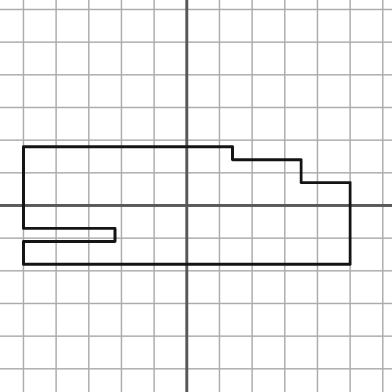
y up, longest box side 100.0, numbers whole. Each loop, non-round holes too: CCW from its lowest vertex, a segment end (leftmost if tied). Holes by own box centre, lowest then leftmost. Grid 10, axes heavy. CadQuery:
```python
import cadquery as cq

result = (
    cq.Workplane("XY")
    .moveTo(-50.0, -18.0)
    .lineTo(50.0, -18.0)
    .lineTo(50.0, 7.0)
    .lineTo(35.0, 7.0)
    .lineTo(35.0, 14.0)
    .lineTo(14.0, 14.0)
    .lineTo(14.0, 18.0)
    .lineTo(-50.0, 18.0)
    .lineTo(-50.0, -7.0)
    .lineTo(-22.0, -7.0)
    .lineTo(-22.0, -11.0)
    .lineTo(-50.0, -11.0)
    .close()
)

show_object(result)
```